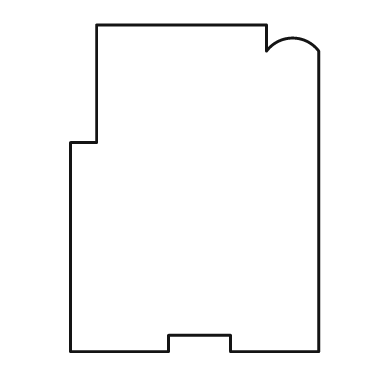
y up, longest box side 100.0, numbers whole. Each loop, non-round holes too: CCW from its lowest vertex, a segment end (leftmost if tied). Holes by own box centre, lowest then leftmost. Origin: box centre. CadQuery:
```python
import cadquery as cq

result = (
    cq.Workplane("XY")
    .moveTo(-38.0, -50.0)
    .lineTo(-8.0, -50.0)
    .lineTo(-8.0, -45.0)
    .lineTo(11.0, -45.0)
    .lineTo(11.0, -50.0)
    .lineTo(38.0, -50.0)
    .lineTo(38.0, 42.0)
    .threePointArc((30.0, 46.0), (22.0, 42.0))
    .lineTo(22.0, 50.0)
    .lineTo(-30.0, 50.0)
    .lineTo(-30.0, 14.0)
    .lineTo(-38.0, 14.0)
    .close()
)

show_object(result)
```